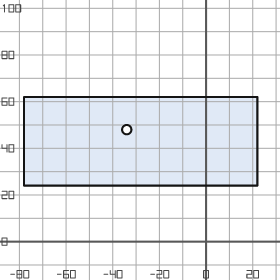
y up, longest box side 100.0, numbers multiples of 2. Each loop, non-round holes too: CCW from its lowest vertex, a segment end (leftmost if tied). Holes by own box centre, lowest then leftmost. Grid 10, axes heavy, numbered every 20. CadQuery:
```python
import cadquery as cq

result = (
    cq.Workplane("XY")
    .moveTo(-78.0, 24.0)
    .lineTo(22.0, 24.0)
    .lineTo(22.0, 62.0)
    .lineTo(-78.0, 62.0)
    .close()
    .moveTo(-34.0, 48.0)
    .circle(2.0)
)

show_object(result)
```